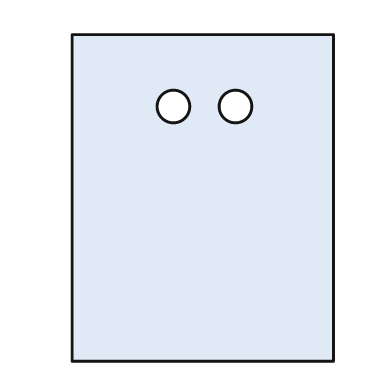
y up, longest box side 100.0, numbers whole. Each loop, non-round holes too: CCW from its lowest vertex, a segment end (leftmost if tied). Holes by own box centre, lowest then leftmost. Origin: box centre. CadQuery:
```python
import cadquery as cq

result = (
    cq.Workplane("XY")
    .moveTo(-40.0, -50.0)
    .lineTo(40.0, -50.0)
    .lineTo(40.0, 50.0)
    .lineTo(-40.0, 50.0)
    .close()
    .moveTo(-9.0, 28.0)
    .circle(5.0)
    .moveTo(10.0, 28.0)
    .circle(5.0)
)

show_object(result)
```